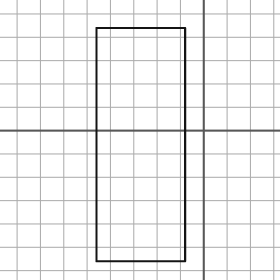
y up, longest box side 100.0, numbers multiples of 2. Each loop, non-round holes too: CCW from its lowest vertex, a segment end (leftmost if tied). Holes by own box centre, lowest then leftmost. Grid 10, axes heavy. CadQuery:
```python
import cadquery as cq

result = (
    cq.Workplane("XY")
    .moveTo(-46.0, -56.0)
    .lineTo(-8.0, -56.0)
    .lineTo(-8.0, 44.0)
    .lineTo(-46.0, 44.0)
    .close()
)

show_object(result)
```